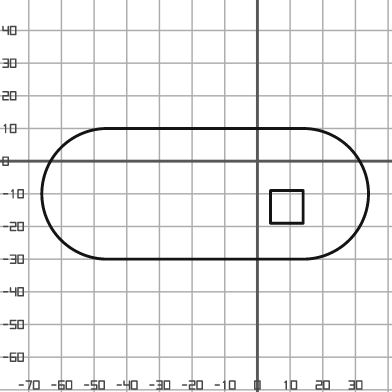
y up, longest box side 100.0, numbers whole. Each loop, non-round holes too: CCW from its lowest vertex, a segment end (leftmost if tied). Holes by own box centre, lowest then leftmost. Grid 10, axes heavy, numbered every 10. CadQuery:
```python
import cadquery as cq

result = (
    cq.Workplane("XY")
    .moveTo(-46.0, -30.0)
    .lineTo(14.0, -30.0)
    .threePointArc((34.0, -10.0), (14.0, 10.0))
    .lineTo(-46.0, 10.0)
    .threePointArc((-66.0, -10.0), (-46.0, -30.0))
    .close()
    .moveTo(4.0, -19.0)
    .lineTo(14.0, -19.0)
    .lineTo(14.0, -9.0)
    .lineTo(4.0, -9.0)
    .close()
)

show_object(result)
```